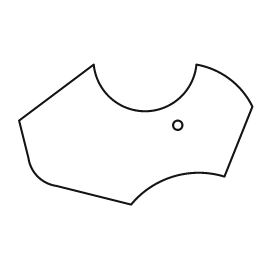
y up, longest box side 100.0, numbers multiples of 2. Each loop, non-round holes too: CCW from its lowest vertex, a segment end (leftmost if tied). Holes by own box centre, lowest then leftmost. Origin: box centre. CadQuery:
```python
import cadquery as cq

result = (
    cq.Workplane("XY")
    .moveTo(-2.0, -30.0)
    .threePointArc((16.0, -18.0), (38.0, -18.0))
    .lineTo(50.0, 12.0)
    .threePointArc((40.0, 24.0), (26.0, 30.0))
    .threePointArc((4.0, 10.0), (-18.0, 30.0))
    .lineTo(-50.0, 6.0)
    .lineTo(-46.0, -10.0)
    .threePointArc((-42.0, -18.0), (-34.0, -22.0))
    .close()
    .moveTo(18.0, 4.0)
    .circle(2.0)
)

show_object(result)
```